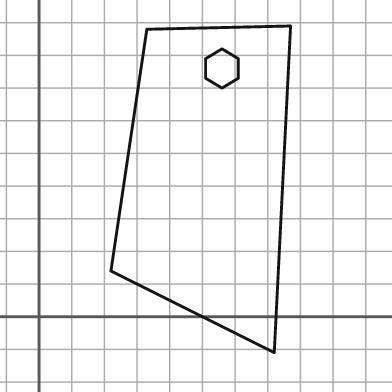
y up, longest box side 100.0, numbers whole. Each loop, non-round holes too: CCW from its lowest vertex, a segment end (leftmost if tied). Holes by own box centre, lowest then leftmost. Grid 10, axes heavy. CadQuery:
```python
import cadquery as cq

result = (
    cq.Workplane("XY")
    .moveTo(72.0, -11.0)
    .lineTo(77.0, 89.0)
    .lineTo(33.0, 88.0)
    .lineTo(22.0, 14.0)
    .close()
    .moveTo(56.0, 70.0)
    .lineTo(61.0, 73.0)
    .lineTo(61.0, 79.0)
    .lineTo(56.0, 82.0)
    .lineTo(51.0, 79.0)
    .lineTo(51.0, 73.0)
    .close()
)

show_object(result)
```